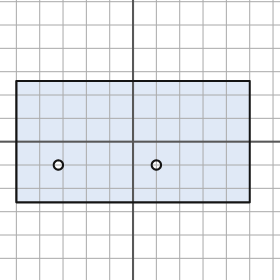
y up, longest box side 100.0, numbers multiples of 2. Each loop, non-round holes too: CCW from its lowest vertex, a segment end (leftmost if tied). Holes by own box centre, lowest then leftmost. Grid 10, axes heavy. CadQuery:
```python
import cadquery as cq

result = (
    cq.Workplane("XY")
    .moveTo(-50.0, -26.0)
    .lineTo(50.0, -26.0)
    .lineTo(50.0, 26.0)
    .lineTo(-50.0, 26.0)
    .close()
    .moveTo(-32.0, -10.0)
    .circle(2.0)
    .moveTo(10.0, -10.0)
    .circle(2.0)
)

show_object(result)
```